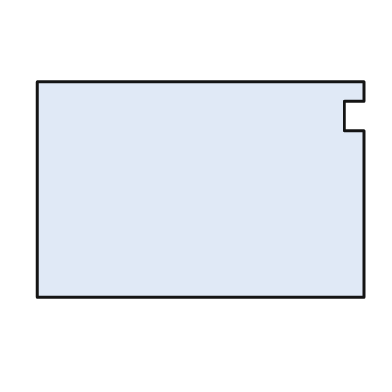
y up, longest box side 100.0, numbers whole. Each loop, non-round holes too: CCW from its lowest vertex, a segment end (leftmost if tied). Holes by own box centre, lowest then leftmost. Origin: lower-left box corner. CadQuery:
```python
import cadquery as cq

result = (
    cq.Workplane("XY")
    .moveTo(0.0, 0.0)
    .lineTo(100.0, 0.0)
    .lineTo(100.0, 51.0)
    .lineTo(94.0, 51.0)
    .lineTo(94.0, 60.0)
    .lineTo(100.0, 60.0)
    .lineTo(100.0, 66.0)
    .lineTo(0.0, 66.0)
    .close()
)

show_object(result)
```